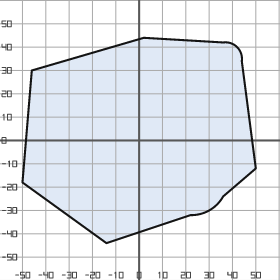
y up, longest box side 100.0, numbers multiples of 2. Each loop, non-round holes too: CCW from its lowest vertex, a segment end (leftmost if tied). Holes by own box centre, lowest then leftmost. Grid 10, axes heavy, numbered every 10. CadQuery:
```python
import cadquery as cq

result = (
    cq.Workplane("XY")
    .moveTo(-14.0, -44.0)
    .lineTo(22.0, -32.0)
    .threePointArc((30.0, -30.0), (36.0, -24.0))
    .lineTo(50.0, -12.0)
    .lineTo(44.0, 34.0)
    .threePointArc((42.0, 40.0), (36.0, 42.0))
    .lineTo(2.0, 44.0)
    .lineTo(-46.0, 30.0)
    .lineTo(-50.0, -18.0)
    .close()
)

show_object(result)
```